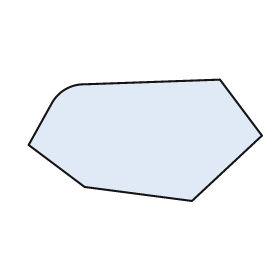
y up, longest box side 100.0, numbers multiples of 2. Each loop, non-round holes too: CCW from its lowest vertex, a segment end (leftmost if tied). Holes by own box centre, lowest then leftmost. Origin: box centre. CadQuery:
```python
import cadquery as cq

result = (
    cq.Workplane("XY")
    .moveTo(20.0, -26.0)
    .lineTo(50.0, 2.0)
    .lineTo(32.0, 26.0)
    .lineTo(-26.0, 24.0)
    .threePointArc((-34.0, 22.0), (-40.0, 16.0))
    .lineTo(-50.0, -2.0)
    .lineTo(-26.0, -20.0)
    .close()
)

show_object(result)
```